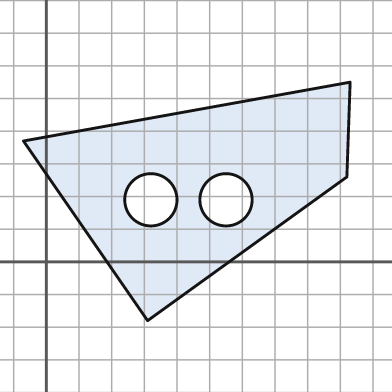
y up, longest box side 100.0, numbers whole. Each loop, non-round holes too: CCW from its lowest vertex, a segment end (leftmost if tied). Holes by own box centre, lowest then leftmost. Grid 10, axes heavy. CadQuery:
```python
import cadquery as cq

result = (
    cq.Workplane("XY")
    .moveTo(31.0, -18.0)
    .lineTo(92.0, 26.0)
    .lineTo(93.0, 55.0)
    .lineTo(-7.0, 37.0)
    .close()
    .moveTo(32.0, 19.0)
    .circle(8.0)
    .moveTo(55.0, 19.0)
    .circle(8.0)
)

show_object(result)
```